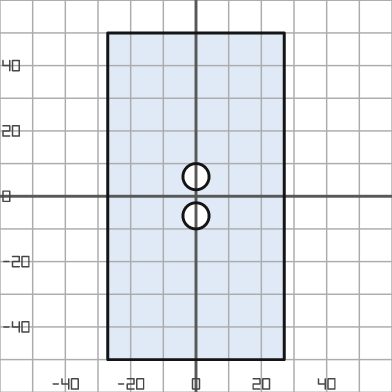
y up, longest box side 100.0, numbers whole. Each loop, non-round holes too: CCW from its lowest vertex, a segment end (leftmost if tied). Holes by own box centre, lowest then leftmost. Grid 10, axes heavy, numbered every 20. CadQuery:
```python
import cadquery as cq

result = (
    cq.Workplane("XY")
    .moveTo(-27.0, -50.0)
    .lineTo(27.0, -50.0)
    .lineTo(27.0, 50.0)
    .lineTo(-27.0, 50.0)
    .close()
    .moveTo(0.0, -6.0)
    .circle(4.0)
    .moveTo(0.0, 6.0)
    .circle(4.0)
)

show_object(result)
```